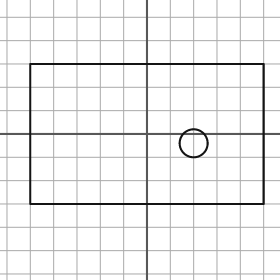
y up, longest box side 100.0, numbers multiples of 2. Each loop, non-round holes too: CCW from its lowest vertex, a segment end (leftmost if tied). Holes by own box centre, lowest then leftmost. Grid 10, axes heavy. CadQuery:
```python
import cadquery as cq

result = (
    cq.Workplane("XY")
    .moveTo(-50.0, -30.0)
    .lineTo(50.0, -30.0)
    .lineTo(50.0, 30.0)
    .lineTo(-50.0, 30.0)
    .close()
    .moveTo(20.0, -4.0)
    .circle(6.0)
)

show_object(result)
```